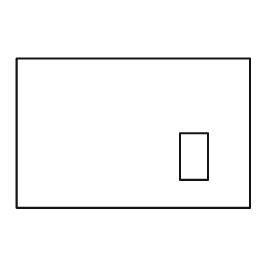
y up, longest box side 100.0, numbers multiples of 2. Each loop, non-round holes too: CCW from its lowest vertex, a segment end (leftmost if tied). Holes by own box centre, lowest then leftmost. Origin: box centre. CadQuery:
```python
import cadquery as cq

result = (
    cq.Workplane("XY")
    .moveTo(-50.0, -32.0)
    .lineTo(50.0, -32.0)
    .lineTo(50.0, 32.0)
    .lineTo(-50.0, 32.0)
    .close()
    .moveTo(20.0, -20.0)
    .lineTo(32.0, -20.0)
    .lineTo(32.0, 0.0)
    .lineTo(20.0, 0.0)
    .close()
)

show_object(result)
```